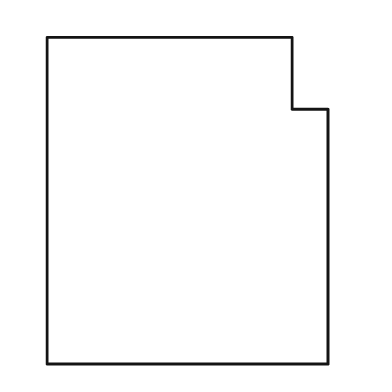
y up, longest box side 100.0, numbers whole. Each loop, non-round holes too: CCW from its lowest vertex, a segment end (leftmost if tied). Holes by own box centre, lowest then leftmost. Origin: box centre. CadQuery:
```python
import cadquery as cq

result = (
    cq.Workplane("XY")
    .moveTo(-43.0, -50.0)
    .lineTo(43.0, -50.0)
    .lineTo(43.0, 28.0)
    .lineTo(32.0, 28.0)
    .lineTo(32.0, 50.0)
    .lineTo(-43.0, 50.0)
    .close()
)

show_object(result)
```